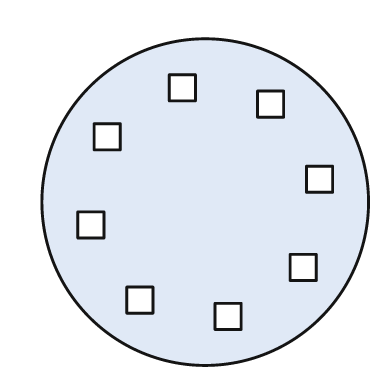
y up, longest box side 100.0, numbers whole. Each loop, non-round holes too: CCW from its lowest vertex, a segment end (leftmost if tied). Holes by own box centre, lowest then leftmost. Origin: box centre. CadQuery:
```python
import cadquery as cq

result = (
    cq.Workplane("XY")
    .moveTo(0.0, 0.0)
    .circle(50.0)
    .moveTo(3.0, -39.0)
    .lineTo(11.0, -39.0)
    .lineTo(11.0, -31.0)
    .lineTo(3.0, -31.0)
    .close()
    .moveTo(-24.0, -34.0)
    .lineTo(-16.0, -34.0)
    .lineTo(-16.0, -26.0)
    .lineTo(-24.0, -26.0)
    .close()
    .moveTo(26.0, -24.0)
    .lineTo(34.0, -24.0)
    .lineTo(34.0, -16.0)
    .lineTo(26.0, -16.0)
    .close()
    .moveTo(-39.0, -11.0)
    .lineTo(-31.0, -11.0)
    .lineTo(-31.0, -3.0)
    .lineTo(-39.0, -3.0)
    .close()
    .moveTo(31.0, 3.0)
    .lineTo(39.0, 3.0)
    .lineTo(39.0, 11.0)
    .lineTo(31.0, 11.0)
    .close()
    .moveTo(-34.0, 16.0)
    .lineTo(-26.0, 16.0)
    .lineTo(-26.0, 24.0)
    .lineTo(-34.0, 24.0)
    .close()
    .moveTo(16.0, 26.0)
    .lineTo(24.0, 26.0)
    .lineTo(24.0, 34.0)
    .lineTo(16.0, 34.0)
    .close()
    .moveTo(-11.0, 31.0)
    .lineTo(-3.0, 31.0)
    .lineTo(-3.0, 39.0)
    .lineTo(-11.0, 39.0)
    .close()
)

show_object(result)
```